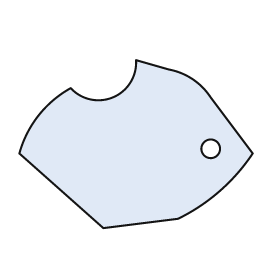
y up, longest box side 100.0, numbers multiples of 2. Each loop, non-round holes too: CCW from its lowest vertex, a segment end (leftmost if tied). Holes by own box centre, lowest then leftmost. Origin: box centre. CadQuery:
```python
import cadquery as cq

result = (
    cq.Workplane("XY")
    .moveTo(-14.0, -36.0)
    .lineTo(18.0, -32.0)
    .threePointArc((36.0, -20.0), (50.0, -4.0))
    .lineTo(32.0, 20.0)
    .threePointArc((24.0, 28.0), (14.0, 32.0))
    .lineTo(0.0, 36.0)
    .threePointArc((-10.0, 20.0), (-28.0, 24.0))
    .threePointArc((-42.0, 12.0), (-50.0, -4.0))
    .close()
    .moveTo(32.0, -2.0)
    .circle(4.0)
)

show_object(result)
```